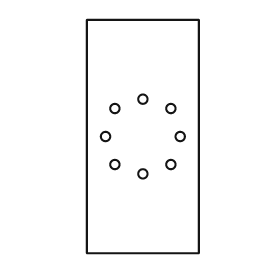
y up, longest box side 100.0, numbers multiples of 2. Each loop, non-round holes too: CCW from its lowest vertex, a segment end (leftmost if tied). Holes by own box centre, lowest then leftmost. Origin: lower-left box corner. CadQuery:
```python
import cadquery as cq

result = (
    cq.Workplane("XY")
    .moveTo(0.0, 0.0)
    .lineTo(48.0, 0.0)
    .lineTo(48.0, 100.0)
    .lineTo(0.0, 100.0)
    .close()
    .moveTo(24.0, 34.0)
    .circle(2.0)
    .moveTo(12.0, 38.0)
    .circle(2.0)
    .moveTo(36.0, 38.0)
    .circle(2.0)
    .moveTo(8.0, 50.0)
    .circle(2.0)
    .moveTo(40.0, 50.0)
    .circle(2.0)
    .moveTo(12.0, 62.0)
    .circle(2.0)
    .moveTo(36.0, 62.0)
    .circle(2.0)
    .moveTo(24.0, 66.0)
    .circle(2.0)
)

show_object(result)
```